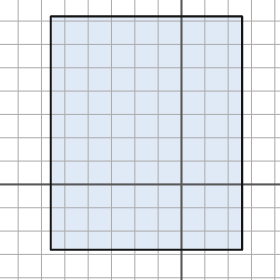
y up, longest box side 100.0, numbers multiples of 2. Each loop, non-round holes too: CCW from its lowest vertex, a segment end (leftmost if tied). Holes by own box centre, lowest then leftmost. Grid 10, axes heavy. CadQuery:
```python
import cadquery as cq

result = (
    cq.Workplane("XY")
    .moveTo(-56.0, -28.0)
    .lineTo(26.0, -28.0)
    .lineTo(26.0, 72.0)
    .lineTo(-56.0, 72.0)
    .close()
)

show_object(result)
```